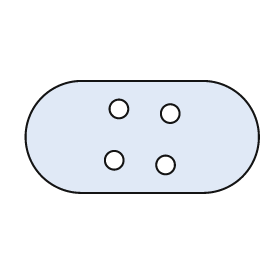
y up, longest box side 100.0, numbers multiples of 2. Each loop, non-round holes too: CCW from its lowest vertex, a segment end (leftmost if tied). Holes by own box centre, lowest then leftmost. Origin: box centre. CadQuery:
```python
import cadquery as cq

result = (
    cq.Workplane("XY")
    .moveTo(-26.0, -24.0)
    .lineTo(26.0, -24.0)
    .threePointArc((50.0, 0.0), (26.0, 24.0))
    .lineTo(-26.0, 24.0)
    .threePointArc((-50.0, 0.0), (-26.0, -24.0))
    .close()
    .moveTo(10.0, -12.0)
    .circle(4.0)
    .moveTo(-12.0, -10.0)
    .circle(4.0)
    .moveTo(12.0, 10.0)
    .circle(4.0)
    .moveTo(-10.0, 12.0)
    .circle(4.0)
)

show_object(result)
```